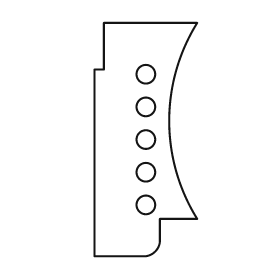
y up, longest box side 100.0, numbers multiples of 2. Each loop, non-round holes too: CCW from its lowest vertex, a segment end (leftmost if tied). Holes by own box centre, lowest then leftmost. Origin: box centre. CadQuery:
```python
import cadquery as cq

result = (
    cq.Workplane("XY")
    .moveTo(-22.0, -50.0)
    .lineTo(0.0, -50.0)
    .threePointArc((4.0, -48.0), (6.0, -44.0))
    .lineTo(6.0, -34.0)
    .lineTo(22.0, -34.0)
    .threePointArc((10.0, 8.0), (22.0, 50.0))
    .lineTo(-18.0, 50.0)
    .lineTo(-18.0, 30.0)
    .lineTo(-22.0, 30.0)
    .close()
    .moveTo(0.0, -28.0)
    .circle(4.0)
    .moveTo(0.0, -14.0)
    .circle(4.0)
    .moveTo(0.0, 0.0)
    .circle(4.0)
    .moveTo(0.0, 14.0)
    .circle(4.0)
    .moveTo(0.0, 28.0)
    .circle(4.0)
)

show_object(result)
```